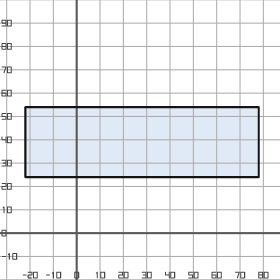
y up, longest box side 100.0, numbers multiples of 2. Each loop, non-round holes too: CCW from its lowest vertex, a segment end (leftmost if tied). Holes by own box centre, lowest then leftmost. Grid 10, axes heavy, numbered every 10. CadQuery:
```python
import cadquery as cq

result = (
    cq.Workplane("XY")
    .moveTo(-22.0, 24.0)
    .lineTo(78.0, 24.0)
    .lineTo(78.0, 54.0)
    .lineTo(-22.0, 54.0)
    .close()
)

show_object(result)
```